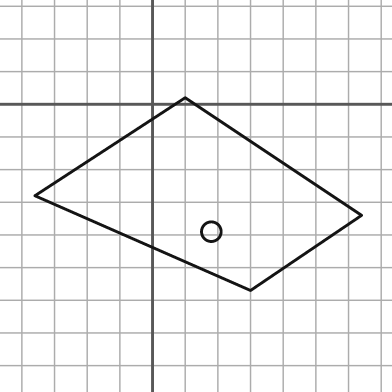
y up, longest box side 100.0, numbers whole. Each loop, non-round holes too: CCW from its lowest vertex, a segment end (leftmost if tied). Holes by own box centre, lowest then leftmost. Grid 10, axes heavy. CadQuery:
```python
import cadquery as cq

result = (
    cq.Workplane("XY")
    .moveTo(30.0, -57.0)
    .lineTo(64.0, -34.0)
    .lineTo(10.0, 2.0)
    .lineTo(-36.0, -28.0)
    .close()
    .moveTo(18.0, -39.0)
    .circle(3.0)
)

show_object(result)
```